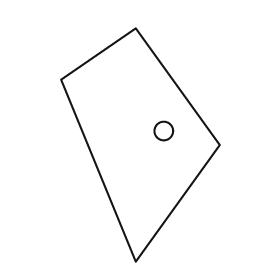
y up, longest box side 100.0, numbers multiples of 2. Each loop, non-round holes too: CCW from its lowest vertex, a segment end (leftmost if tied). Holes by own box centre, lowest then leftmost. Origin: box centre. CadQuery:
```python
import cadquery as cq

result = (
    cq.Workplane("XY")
    .moveTo(-2.0, -50.0)
    .lineTo(34.0, 0.0)
    .lineTo(-2.0, 50.0)
    .lineTo(-34.0, 28.0)
    .close()
    .moveTo(10.0, 6.0)
    .circle(4.0)
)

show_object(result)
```